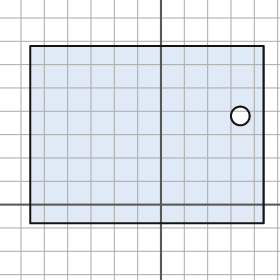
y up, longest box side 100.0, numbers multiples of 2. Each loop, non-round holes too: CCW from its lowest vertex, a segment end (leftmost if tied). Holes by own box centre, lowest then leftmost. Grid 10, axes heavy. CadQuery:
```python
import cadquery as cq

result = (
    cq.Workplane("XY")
    .moveTo(-56.0, -8.0)
    .lineTo(44.0, -8.0)
    .lineTo(44.0, 68.0)
    .lineTo(-56.0, 68.0)
    .close()
    .moveTo(34.0, 38.0)
    .circle(4.0)
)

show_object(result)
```